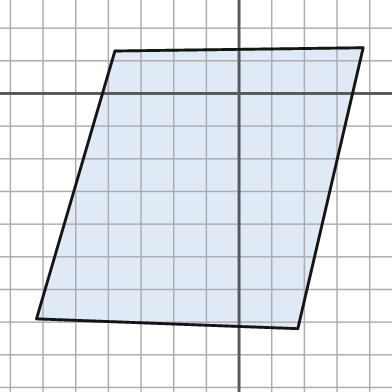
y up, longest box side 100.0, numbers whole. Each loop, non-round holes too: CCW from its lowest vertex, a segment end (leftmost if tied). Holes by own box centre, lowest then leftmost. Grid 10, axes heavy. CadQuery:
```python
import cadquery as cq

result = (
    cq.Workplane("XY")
    .moveTo(18.0, -72.0)
    .lineTo(38.0, 14.0)
    .lineTo(-38.0, 13.0)
    .lineTo(-62.0, -69.0)
    .close()
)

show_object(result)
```